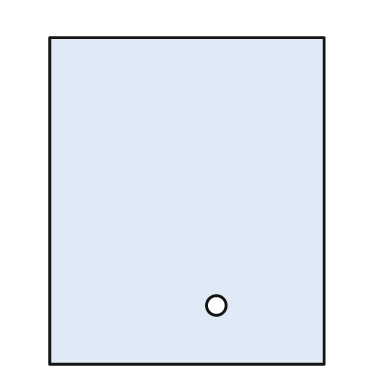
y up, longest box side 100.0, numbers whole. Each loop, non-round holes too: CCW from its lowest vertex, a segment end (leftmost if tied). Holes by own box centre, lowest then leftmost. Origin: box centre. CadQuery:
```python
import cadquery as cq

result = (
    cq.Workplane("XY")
    .moveTo(-42.0, -50.0)
    .lineTo(42.0, -50.0)
    .lineTo(42.0, 50.0)
    .lineTo(-42.0, 50.0)
    .close()
    .moveTo(9.0, -32.0)
    .circle(3.0)
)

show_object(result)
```